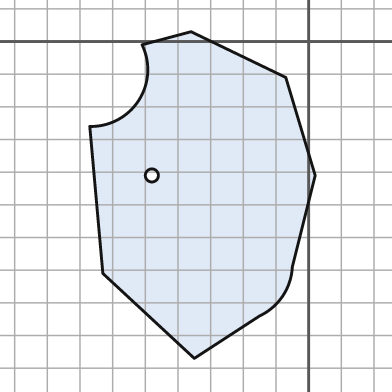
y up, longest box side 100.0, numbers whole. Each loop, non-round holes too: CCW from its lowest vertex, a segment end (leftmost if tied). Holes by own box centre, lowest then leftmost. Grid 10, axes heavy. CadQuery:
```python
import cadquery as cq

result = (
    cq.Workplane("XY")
    .moveTo(-35.0, -97.0)
    .lineTo(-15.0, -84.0)
    .threePointArc((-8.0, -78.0), (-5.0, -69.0))
    .lineTo(2.0, -41.0)
    .lineTo(-7.0, -11.0)
    .lineTo(-36.0, 3.0)
    .lineTo(-51.0, -1.0)
    .threePointArc((-52.0, -18.0), (-67.0, -26.0))
    .lineTo(-63.0, -71.0)
    .close()
    .moveTo(-48.0, -41.0)
    .circle(2.0)
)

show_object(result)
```